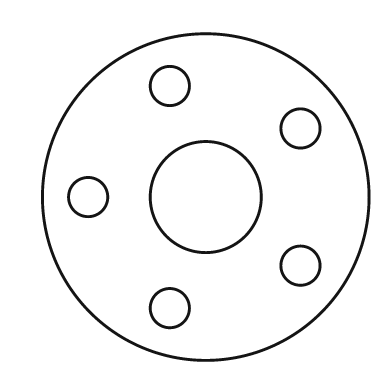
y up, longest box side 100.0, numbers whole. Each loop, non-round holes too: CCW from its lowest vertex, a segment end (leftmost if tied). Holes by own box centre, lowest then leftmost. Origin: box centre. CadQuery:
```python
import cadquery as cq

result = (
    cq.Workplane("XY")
    .moveTo(0.0, 0.0)
    .circle(50.0)
    .moveTo(-11.0, -34.0)
    .circle(6.0)
    .moveTo(29.0, -21.0)
    .circle(6.0)
    .moveTo(-36.0, 0.0)
    .circle(6.0)
    .moveTo(0.0, 0.0)
    .circle(17.0)
    .moveTo(29.0, 21.0)
    .circle(6.0)
    .moveTo(-11.0, 34.0)
    .circle(6.0)
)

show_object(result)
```